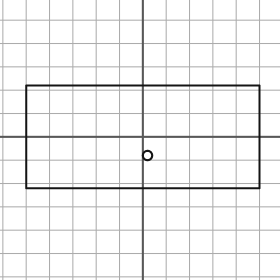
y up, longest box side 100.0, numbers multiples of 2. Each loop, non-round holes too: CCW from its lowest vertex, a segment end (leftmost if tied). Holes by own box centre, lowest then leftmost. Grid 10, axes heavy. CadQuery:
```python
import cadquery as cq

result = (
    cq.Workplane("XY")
    .moveTo(-50.0, -22.0)
    .lineTo(50.0, -22.0)
    .lineTo(50.0, 22.0)
    .lineTo(-50.0, 22.0)
    .close()
    .moveTo(2.0, -8.0)
    .circle(2.0)
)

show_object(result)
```